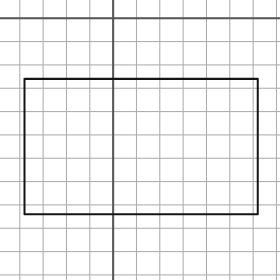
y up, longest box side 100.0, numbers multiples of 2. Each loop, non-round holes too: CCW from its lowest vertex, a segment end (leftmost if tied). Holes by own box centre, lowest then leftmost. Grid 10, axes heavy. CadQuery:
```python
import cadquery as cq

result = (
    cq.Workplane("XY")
    .moveTo(-38.0, -84.0)
    .lineTo(62.0, -84.0)
    .lineTo(62.0, -26.0)
    .lineTo(-38.0, -26.0)
    .close()
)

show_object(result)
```